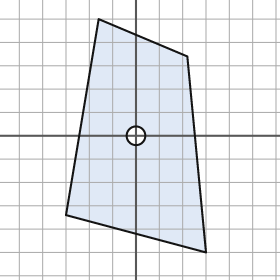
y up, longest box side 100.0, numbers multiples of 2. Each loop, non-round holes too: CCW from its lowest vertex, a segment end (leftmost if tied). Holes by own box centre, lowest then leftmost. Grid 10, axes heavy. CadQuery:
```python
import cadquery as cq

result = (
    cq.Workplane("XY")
    .moveTo(30.0, -50.0)
    .lineTo(22.0, 34.0)
    .lineTo(-16.0, 50.0)
    .lineTo(-30.0, -34.0)
    .close()
    .moveTo(0.0, 0.0)
    .circle(4.0)
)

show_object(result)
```